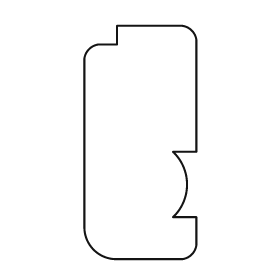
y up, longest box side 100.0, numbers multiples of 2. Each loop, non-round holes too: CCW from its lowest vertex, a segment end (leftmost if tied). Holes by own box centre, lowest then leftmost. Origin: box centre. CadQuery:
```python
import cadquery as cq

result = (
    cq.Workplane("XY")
    .moveTo(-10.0, -50.0)
    .lineTo(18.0, -50.0)
    .threePointArc((22.0, -48.0), (24.0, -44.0))
    .lineTo(24.0, -32.0)
    .lineTo(14.0, -32.0)
    .threePointArc((20.0, -18.0), (14.0, -4.0))
    .lineTo(24.0, -4.0)
    .lineTo(24.0, 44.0)
    .threePointArc((22.0, 48.0), (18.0, 50.0))
    .lineTo(-10.0, 50.0)
    .lineTo(-10.0, 42.0)
    .lineTo(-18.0, 42.0)
    .threePointArc((-22.0, 40.0), (-24.0, 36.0))
    .lineTo(-24.0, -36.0)
    .threePointArc((-20.0, -46.0), (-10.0, -50.0))
    .close()
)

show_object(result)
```